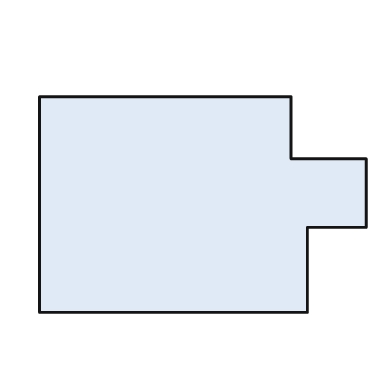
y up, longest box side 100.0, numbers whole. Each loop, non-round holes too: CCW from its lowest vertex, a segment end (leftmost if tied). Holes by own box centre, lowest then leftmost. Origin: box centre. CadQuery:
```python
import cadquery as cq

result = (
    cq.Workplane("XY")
    .moveTo(-50.0, -33.0)
    .lineTo(32.0, -33.0)
    .lineTo(32.0, -7.0)
    .lineTo(50.0, -7.0)
    .lineTo(50.0, 14.0)
    .lineTo(27.0, 14.0)
    .lineTo(27.0, 33.0)
    .lineTo(-50.0, 33.0)
    .close()
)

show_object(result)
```